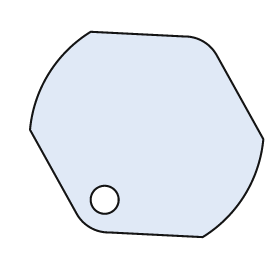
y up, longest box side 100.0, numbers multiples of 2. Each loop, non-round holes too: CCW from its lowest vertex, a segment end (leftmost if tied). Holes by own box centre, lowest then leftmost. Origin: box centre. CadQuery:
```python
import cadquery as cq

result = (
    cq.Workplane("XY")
    .moveTo(24.0, -44.0)
    .threePointArc((42.0, -26.0), (50.0, -2.0))
    .lineTo(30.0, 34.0)
    .threePointArc((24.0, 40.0), (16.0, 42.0))
    .lineTo(-24.0, 44.0)
    .threePointArc((-42.0, 26.0), (-50.0, 2.0))
    .lineTo(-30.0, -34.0)
    .threePointArc((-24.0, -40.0), (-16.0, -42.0))
    .close()
    .moveTo(-18.0, -28.0)
    .circle(6.0)
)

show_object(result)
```